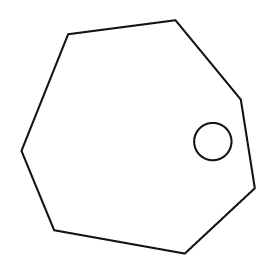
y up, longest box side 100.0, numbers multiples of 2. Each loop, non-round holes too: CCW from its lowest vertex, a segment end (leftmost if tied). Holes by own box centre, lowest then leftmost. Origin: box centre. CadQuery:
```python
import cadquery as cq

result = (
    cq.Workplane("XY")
    .moveTo(20.0, -50.0)
    .lineTo(50.0, -22.0)
    .lineTo(44.0, 16.0)
    .lineTo(16.0, 50.0)
    .lineTo(-30.0, 44.0)
    .lineTo(-50.0, -6.0)
    .lineTo(-36.0, -40.0)
    .close()
    .moveTo(32.0, -2.0)
    .circle(8.0)
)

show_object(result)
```